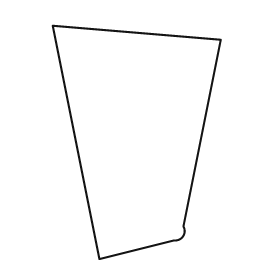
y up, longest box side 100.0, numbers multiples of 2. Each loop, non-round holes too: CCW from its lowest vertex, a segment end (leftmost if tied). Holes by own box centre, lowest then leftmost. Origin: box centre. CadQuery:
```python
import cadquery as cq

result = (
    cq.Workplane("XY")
    .moveTo(-16.0, -50.0)
    .lineTo(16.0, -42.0)
    .threePointArc((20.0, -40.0), (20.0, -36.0))
    .lineTo(36.0, 44.0)
    .lineTo(-36.0, 50.0)
    .close()
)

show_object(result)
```